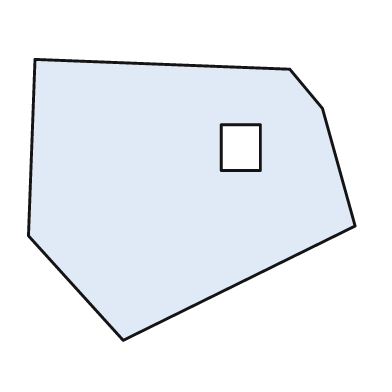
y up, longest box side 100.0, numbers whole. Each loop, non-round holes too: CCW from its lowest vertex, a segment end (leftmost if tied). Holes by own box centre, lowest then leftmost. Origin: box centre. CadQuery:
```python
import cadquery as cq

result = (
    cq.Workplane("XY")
    .moveTo(-21.0, -43.0)
    .lineTo(50.0, -8.0)
    .lineTo(40.0, 28.0)
    .lineTo(30.0, 40.0)
    .lineTo(-48.0, 43.0)
    .lineTo(-50.0, -11.0)
    .close()
    .moveTo(9.0, 9.0)
    .lineTo(21.0, 9.0)
    .lineTo(21.0, 23.0)
    .lineTo(9.0, 23.0)
    .close()
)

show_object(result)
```